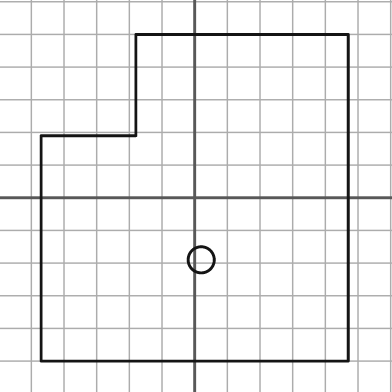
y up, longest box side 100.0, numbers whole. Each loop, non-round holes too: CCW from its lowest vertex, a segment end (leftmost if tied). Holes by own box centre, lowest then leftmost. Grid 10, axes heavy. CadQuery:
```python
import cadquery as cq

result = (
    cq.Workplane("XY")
    .moveTo(-47.0, -50.0)
    .lineTo(47.0, -50.0)
    .lineTo(47.0, 50.0)
    .lineTo(-18.0, 50.0)
    .lineTo(-18.0, 19.0)
    .lineTo(-47.0, 19.0)
    .close()
    .moveTo(2.0, -19.0)
    .circle(4.0)
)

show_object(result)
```